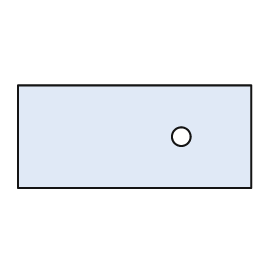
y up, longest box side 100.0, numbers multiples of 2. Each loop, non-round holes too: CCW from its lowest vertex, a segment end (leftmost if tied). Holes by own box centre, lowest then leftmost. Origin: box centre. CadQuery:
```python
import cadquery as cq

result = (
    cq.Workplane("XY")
    .moveTo(-50.0, -22.0)
    .lineTo(50.0, -22.0)
    .lineTo(50.0, 22.0)
    .lineTo(-50.0, 22.0)
    .close()
    .moveTo(20.0, 0.0)
    .circle(4.0)
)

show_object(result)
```